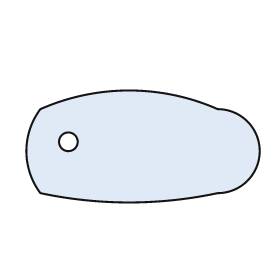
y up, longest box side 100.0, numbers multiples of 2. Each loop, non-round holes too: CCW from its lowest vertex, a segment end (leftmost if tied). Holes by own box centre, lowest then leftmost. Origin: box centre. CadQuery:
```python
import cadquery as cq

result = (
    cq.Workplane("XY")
    .moveTo(-44.0, -20.0)
    .threePointArc((-6.0, -24.0), (32.0, -20.0))
    .threePointArc((50.0, -2.0), (32.0, 16.0))
    .threePointArc((-6.0, 24.0), (-44.0, 16.0))
    .threePointArc((-50.0, -2.0), (-44.0, -20.0))
    .close()
    .moveTo(-32.0, 2.0)
    .circle(4.0)
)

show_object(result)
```